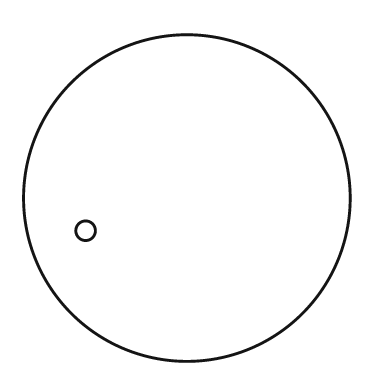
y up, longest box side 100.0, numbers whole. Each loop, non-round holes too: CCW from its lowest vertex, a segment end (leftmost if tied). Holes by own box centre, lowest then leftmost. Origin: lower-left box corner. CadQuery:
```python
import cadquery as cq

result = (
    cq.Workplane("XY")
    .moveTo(50.0, 50.0)
    .circle(50.0)
    .moveTo(19.0, 40.0)
    .circle(3.0)
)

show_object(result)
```